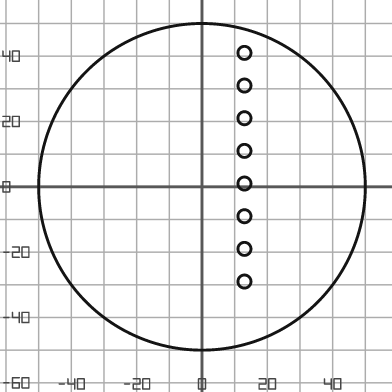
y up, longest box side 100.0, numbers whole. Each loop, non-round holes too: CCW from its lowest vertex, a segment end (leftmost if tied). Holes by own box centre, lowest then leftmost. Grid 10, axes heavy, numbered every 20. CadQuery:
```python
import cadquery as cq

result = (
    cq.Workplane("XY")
    .moveTo(0.0, 0.0)
    .circle(50.0)
    .moveTo(13.0, -29.0)
    .circle(2.0)
    .moveTo(13.0, -19.0)
    .circle(2.0)
    .moveTo(13.0, -9.0)
    .circle(2.0)
    .moveTo(13.0, 1.0)
    .circle(2.0)
    .moveTo(13.0, 11.0)
    .circle(2.0)
    .moveTo(13.0, 21.0)
    .circle(2.0)
    .moveTo(13.0, 31.0)
    .circle(2.0)
    .moveTo(13.0, 41.0)
    .circle(2.0)
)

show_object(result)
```